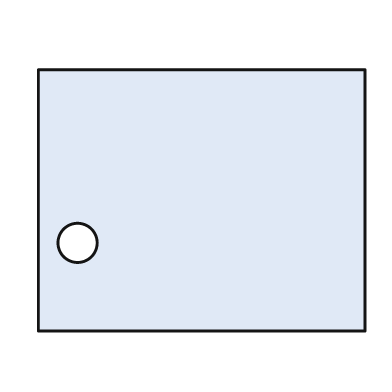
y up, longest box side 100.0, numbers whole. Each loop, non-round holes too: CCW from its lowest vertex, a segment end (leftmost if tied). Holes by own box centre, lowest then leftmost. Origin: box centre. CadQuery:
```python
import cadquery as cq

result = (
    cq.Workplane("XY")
    .moveTo(-50.0, -40.0)
    .lineTo(50.0, -40.0)
    .lineTo(50.0, 40.0)
    .lineTo(-50.0, 40.0)
    .close()
    .moveTo(-38.0, -13.0)
    .circle(6.0)
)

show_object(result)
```